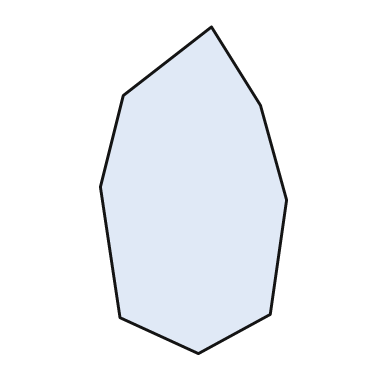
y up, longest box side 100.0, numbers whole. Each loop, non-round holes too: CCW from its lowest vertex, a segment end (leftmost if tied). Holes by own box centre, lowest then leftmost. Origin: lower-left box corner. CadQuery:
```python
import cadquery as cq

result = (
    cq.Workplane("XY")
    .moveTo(30.0, 0.0)
    .lineTo(52.0, 12.0)
    .lineTo(57.0, 47.0)
    .lineTo(49.0, 76.0)
    .lineTo(34.0, 100.0)
    .lineTo(7.0, 79.0)
    .lineTo(0.0, 51.0)
    .lineTo(6.0, 11.0)
    .close()
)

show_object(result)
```